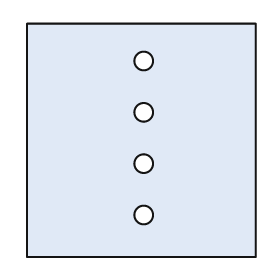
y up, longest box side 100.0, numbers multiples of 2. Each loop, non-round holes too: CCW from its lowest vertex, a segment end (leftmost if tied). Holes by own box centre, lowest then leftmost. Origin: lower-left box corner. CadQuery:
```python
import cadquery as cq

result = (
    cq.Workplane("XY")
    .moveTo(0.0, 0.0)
    .lineTo(98.0, 0.0)
    .lineTo(98.0, 100.0)
    .lineTo(0.0, 100.0)
    .close()
    .moveTo(50.0, 18.0)
    .circle(4.0)
    .moveTo(50.0, 40.0)
    .circle(4.0)
    .moveTo(50.0, 62.0)
    .circle(4.0)
    .moveTo(50.0, 84.0)
    .circle(4.0)
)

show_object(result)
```